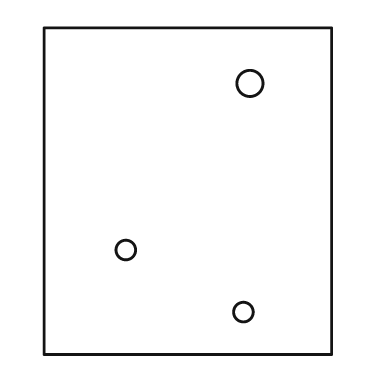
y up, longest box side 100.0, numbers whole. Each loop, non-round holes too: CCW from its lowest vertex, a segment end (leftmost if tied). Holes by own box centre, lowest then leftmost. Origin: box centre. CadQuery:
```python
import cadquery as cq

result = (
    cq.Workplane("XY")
    .moveTo(-44.0, -50.0)
    .lineTo(44.0, -50.0)
    .lineTo(44.0, 50.0)
    .lineTo(-44.0, 50.0)
    .close()
    .moveTo(17.0, -37.0)
    .circle(3.0)
    .moveTo(-19.0, -18.0)
    .circle(3.0)
    .moveTo(19.0, 33.0)
    .circle(4.0)
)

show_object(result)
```